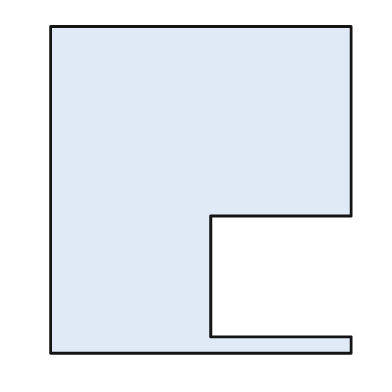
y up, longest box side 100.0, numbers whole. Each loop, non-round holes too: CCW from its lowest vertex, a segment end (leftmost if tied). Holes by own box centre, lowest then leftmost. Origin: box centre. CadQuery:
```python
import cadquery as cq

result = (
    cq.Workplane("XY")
    .moveTo(-46.0, -50.0)
    .lineTo(46.0, -50.0)
    .lineTo(46.0, -45.0)
    .lineTo(3.0, -45.0)
    .lineTo(3.0, -8.0)
    .lineTo(46.0, -8.0)
    .lineTo(46.0, 50.0)
    .lineTo(-46.0, 50.0)
    .close()
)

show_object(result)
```